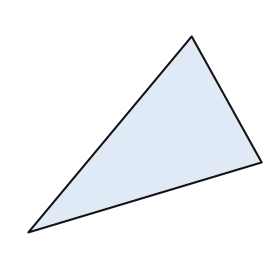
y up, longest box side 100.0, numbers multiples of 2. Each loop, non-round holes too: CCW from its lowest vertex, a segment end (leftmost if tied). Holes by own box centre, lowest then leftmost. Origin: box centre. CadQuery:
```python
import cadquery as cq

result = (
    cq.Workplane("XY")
    .moveTo(-50.0, -42.0)
    .lineTo(50.0, -12.0)
    .lineTo(20.0, 42.0)
    .close()
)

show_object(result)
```